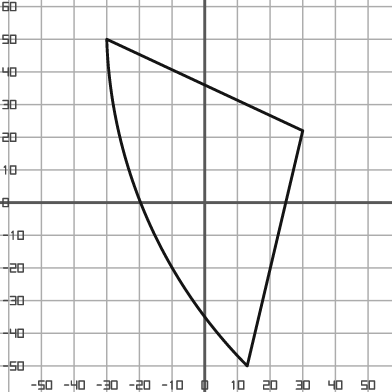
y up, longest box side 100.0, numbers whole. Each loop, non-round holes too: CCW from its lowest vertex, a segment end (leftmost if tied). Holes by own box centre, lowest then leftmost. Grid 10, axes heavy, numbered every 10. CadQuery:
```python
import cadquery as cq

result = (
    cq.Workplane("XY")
    .moveTo(13.0, -50.0)
    .lineTo(30.0, 22.0)
    .lineTo(-30.0, 50.0)
    .threePointArc((-18.0, -4.0), (13.0, -50.0))
    .close()
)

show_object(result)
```